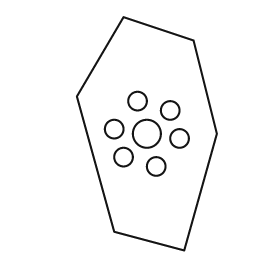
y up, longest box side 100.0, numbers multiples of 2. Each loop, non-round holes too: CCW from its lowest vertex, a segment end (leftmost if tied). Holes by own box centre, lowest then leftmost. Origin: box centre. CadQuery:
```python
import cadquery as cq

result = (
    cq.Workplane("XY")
    .moveTo(16.0, -50.0)
    .lineTo(30.0, 0.0)
    .lineTo(20.0, 40.0)
    .lineTo(-10.0, 50.0)
    .lineTo(-30.0, 16.0)
    .lineTo(-14.0, -42.0)
    .close()
    .moveTo(4.0, -14.0)
    .circle(4.0)
    .moveTo(-10.0, -10.0)
    .circle(4.0)
    .moveTo(14.0, -2.0)
    .circle(4.0)
    .moveTo(0.0, 0.0)
    .circle(6.0)
    .moveTo(-14.0, 2.0)
    .circle(4.0)
    .moveTo(10.0, 10.0)
    .circle(4.0)
    .moveTo(-4.0, 14.0)
    .circle(4.0)
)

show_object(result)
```